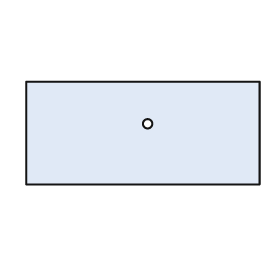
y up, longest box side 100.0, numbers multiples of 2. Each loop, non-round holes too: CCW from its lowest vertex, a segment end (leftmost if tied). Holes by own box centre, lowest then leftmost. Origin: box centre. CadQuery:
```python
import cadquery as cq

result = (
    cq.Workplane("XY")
    .moveTo(-50.0, -22.0)
    .lineTo(50.0, -22.0)
    .lineTo(50.0, 22.0)
    .lineTo(-50.0, 22.0)
    .close()
    .moveTo(2.0, 4.0)
    .circle(2.0)
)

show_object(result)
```